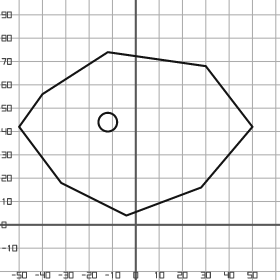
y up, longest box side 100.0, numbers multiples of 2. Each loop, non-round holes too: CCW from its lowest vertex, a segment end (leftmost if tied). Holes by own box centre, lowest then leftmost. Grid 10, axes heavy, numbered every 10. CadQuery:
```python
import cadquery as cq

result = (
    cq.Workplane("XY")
    .moveTo(-4.0, 4.0)
    .lineTo(28.0, 16.0)
    .lineTo(50.0, 42.0)
    .lineTo(30.0, 68.0)
    .lineTo(-12.0, 74.0)
    .lineTo(-40.0, 56.0)
    .lineTo(-50.0, 42.0)
    .lineTo(-32.0, 18.0)
    .close()
    .moveTo(-12.0, 44.0)
    .circle(4.0)
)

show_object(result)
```